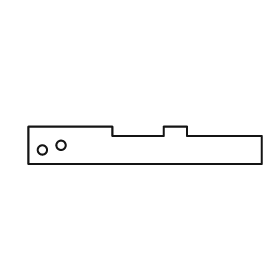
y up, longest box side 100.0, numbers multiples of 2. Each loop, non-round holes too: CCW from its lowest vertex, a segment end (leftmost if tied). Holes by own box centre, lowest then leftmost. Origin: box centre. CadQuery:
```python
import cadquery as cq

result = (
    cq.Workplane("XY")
    .moveTo(-50.0, -8.0)
    .lineTo(50.0, -8.0)
    .lineTo(50.0, 4.0)
    .lineTo(18.0, 4.0)
    .lineTo(18.0, 8.0)
    .lineTo(8.0, 8.0)
    .lineTo(8.0, 4.0)
    .lineTo(-14.0, 4.0)
    .lineTo(-14.0, 8.0)
    .lineTo(-50.0, 8.0)
    .close()
    .moveTo(-44.0, -2.0)
    .circle(2.0)
    .moveTo(-36.0, 0.0)
    .circle(2.0)
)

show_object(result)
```